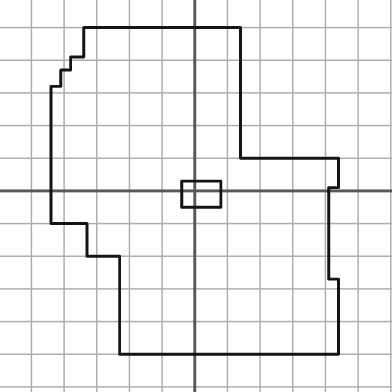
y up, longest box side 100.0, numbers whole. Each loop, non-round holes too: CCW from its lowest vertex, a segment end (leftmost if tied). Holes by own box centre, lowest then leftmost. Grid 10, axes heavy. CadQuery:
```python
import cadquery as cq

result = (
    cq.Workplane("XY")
    .moveTo(-23.0, -50.0)
    .lineTo(44.0, -50.0)
    .lineTo(44.0, -27.0)
    .lineTo(41.0, -27.0)
    .lineTo(41.0, 1.0)
    .lineTo(44.0, 1.0)
    .lineTo(44.0, 10.0)
    .lineTo(14.0, 10.0)
    .lineTo(14.0, 50.0)
    .lineTo(-34.0, 50.0)
    .lineTo(-34.0, 41.0)
    .lineTo(-38.0, 41.0)
    .lineTo(-38.0, 37.0)
    .lineTo(-41.0, 37.0)
    .lineTo(-41.0, 32.0)
    .lineTo(-44.0, 32.0)
    .lineTo(-44.0, -10.0)
    .lineTo(-33.0, -10.0)
    .lineTo(-33.0, -20.0)
    .lineTo(-23.0, -20.0)
    .close()
    .moveTo(-4.0, -5.0)
    .lineTo(8.0, -5.0)
    .lineTo(8.0, 3.0)
    .lineTo(-4.0, 3.0)
    .close()
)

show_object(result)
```